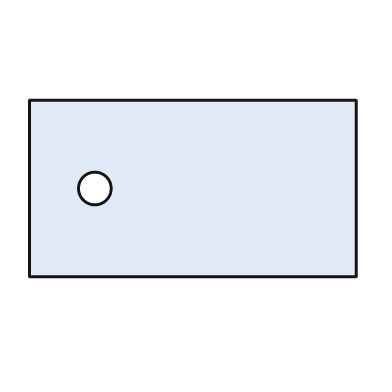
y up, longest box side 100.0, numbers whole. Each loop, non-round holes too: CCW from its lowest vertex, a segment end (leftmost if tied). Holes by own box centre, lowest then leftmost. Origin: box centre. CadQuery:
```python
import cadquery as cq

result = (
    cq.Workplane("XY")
    .moveTo(-50.0, -27.0)
    .lineTo(50.0, -27.0)
    .lineTo(50.0, 27.0)
    .lineTo(-50.0, 27.0)
    .close()
    .moveTo(-30.0, 0.0)
    .circle(5.0)
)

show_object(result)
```